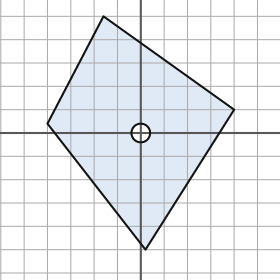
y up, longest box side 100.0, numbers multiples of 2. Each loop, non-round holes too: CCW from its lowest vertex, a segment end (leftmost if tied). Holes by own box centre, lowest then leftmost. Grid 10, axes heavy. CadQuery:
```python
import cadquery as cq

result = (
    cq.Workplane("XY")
    .moveTo(2.0, -50.0)
    .lineTo(40.0, 10.0)
    .lineTo(-16.0, 50.0)
    .lineTo(-40.0, 4.0)
    .close()
    .moveTo(0.0, 0.0)
    .circle(4.0)
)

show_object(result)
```